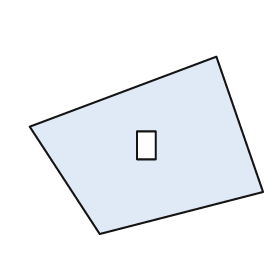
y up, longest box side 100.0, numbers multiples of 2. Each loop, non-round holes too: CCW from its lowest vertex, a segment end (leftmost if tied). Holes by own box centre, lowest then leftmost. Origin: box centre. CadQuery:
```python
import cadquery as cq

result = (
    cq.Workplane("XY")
    .moveTo(-20.0, -38.0)
    .lineTo(50.0, -20.0)
    .lineTo(30.0, 38.0)
    .lineTo(-50.0, 8.0)
    .close()
    .moveTo(-4.0, -6.0)
    .lineTo(4.0, -6.0)
    .lineTo(4.0, 6.0)
    .lineTo(-4.0, 6.0)
    .close()
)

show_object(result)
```